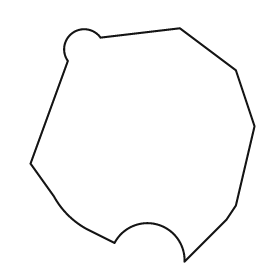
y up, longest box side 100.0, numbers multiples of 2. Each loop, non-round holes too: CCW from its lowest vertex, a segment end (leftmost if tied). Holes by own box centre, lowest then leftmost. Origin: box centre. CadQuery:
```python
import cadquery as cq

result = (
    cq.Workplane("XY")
    .moveTo(18.0, -50.0)
    .lineTo(36.0, -32.0)
    .lineTo(40.0, -26.0)
    .lineTo(48.0, 8.0)
    .lineTo(40.0, 32.0)
    .lineTo(16.0, 50.0)
    .lineTo(-18.0, 46.0)
    .threePointArc((-30.0, 48.0), (-32.0, 36.0))
    .lineTo(-48.0, -8.0)
    .lineTo(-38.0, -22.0)
    .threePointArc((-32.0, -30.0), (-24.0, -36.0))
    .lineTo(-12.0, -42.0)
    .threePointArc((6.0, -34.0), (18.0, -50.0))
    .close()
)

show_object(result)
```